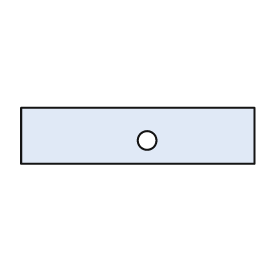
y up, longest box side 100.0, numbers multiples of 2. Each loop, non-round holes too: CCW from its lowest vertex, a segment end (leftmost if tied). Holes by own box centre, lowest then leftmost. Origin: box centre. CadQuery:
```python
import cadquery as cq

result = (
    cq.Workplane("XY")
    .moveTo(-50.0, -12.0)
    .lineTo(50.0, -12.0)
    .lineTo(50.0, 12.0)
    .lineTo(-50.0, 12.0)
    .close()
    .moveTo(4.0, -2.0)
    .circle(4.0)
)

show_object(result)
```